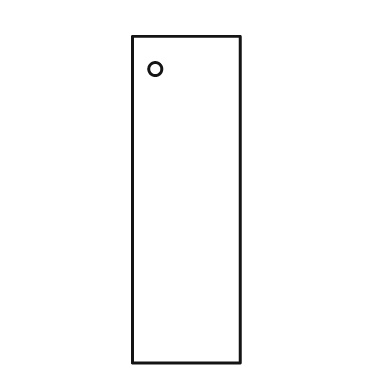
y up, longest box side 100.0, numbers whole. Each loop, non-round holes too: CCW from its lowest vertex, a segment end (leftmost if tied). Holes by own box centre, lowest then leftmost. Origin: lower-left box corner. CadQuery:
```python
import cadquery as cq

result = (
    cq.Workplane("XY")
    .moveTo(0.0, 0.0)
    .lineTo(33.0, 0.0)
    .lineTo(33.0, 100.0)
    .lineTo(0.0, 100.0)
    .close()
    .moveTo(7.0, 90.0)
    .circle(2.0)
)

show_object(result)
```